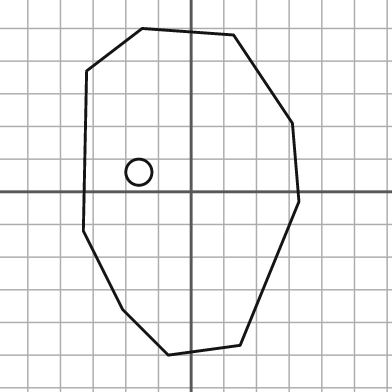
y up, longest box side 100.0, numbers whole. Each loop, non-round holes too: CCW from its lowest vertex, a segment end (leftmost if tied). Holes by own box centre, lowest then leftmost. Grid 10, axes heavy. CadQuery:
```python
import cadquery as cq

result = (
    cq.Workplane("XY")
    .moveTo(-7.0, -50.0)
    .lineTo(15.0, -47.0)
    .lineTo(33.0, -3.0)
    .lineTo(31.0, 21.0)
    .lineTo(13.0, 48.0)
    .lineTo(-15.0, 50.0)
    .lineTo(-32.0, 37.0)
    .lineTo(-33.0, -12.0)
    .lineTo(-21.0, -36.0)
    .close()
    .moveTo(-16.0, 6.0)
    .circle(4.0)
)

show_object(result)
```